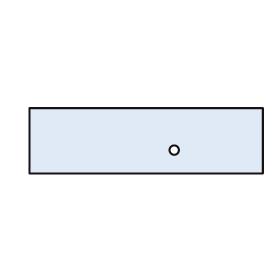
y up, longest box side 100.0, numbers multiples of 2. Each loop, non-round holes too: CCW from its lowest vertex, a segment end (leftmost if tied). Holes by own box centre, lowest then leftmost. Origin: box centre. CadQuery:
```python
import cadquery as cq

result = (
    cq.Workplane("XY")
    .moveTo(-50.0, -14.0)
    .lineTo(50.0, -14.0)
    .lineTo(50.0, 14.0)
    .lineTo(-50.0, 14.0)
    .close()
    .moveTo(12.0, -4.0)
    .circle(2.0)
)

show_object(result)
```